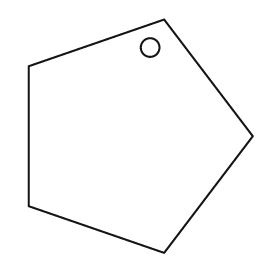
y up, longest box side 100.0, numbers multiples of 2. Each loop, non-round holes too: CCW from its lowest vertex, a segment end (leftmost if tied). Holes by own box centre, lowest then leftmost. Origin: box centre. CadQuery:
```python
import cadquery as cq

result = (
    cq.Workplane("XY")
    .moveTo(10.0, -50.0)
    .lineTo(48.0, 0.0)
    .lineTo(10.0, 50.0)
    .lineTo(-48.0, 30.0)
    .lineTo(-48.0, -30.0)
    .close()
    .moveTo(4.0, 38.0)
    .circle(4.0)
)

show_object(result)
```